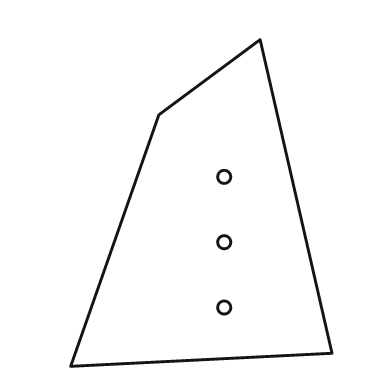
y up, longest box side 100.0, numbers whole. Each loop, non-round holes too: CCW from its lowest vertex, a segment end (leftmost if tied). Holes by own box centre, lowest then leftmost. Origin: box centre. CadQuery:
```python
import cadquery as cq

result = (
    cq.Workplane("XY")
    .moveTo(-40.0, -50.0)
    .lineTo(40.0, -46.0)
    .lineTo(18.0, 50.0)
    .lineTo(-13.0, 27.0)
    .close()
    .moveTo(7.0, -32.0)
    .circle(2.0)
    .moveTo(7.0, -12.0)
    .circle(2.0)
    .moveTo(7.0, 8.0)
    .circle(2.0)
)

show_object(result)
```